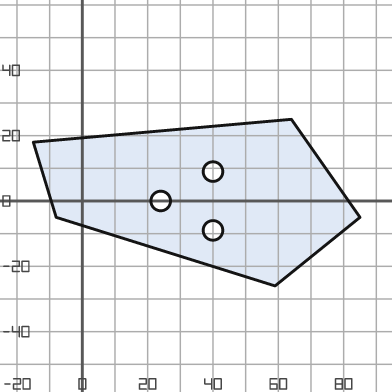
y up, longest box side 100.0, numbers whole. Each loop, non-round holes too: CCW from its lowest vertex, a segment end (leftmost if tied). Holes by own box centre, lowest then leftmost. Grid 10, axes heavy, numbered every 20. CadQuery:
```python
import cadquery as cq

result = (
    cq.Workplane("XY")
    .moveTo(59.0, -26.0)
    .lineTo(85.0, -5.0)
    .lineTo(64.0, 25.0)
    .lineTo(-15.0, 18.0)
    .lineTo(-8.0, -5.0)
    .close()
    .moveTo(40.0, -9.0)
    .circle(3.0)
    .moveTo(24.0, 0.0)
    .circle(3.0)
    .moveTo(40.0, 9.0)
    .circle(3.0)
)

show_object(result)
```